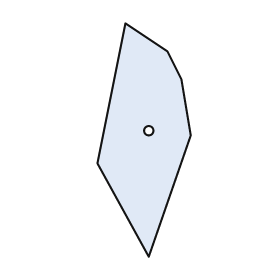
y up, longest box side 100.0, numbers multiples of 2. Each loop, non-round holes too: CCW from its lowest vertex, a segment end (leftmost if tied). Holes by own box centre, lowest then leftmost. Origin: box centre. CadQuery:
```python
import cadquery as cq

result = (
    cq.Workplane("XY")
    .moveTo(2.0, -50.0)
    .lineTo(20.0, 2.0)
    .lineTo(16.0, 26.0)
    .lineTo(10.0, 38.0)
    .lineTo(-8.0, 50.0)
    .lineTo(-20.0, -10.0)
    .close()
    .moveTo(2.0, 4.0)
    .circle(2.0)
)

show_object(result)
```